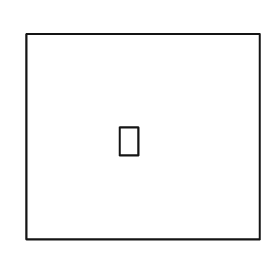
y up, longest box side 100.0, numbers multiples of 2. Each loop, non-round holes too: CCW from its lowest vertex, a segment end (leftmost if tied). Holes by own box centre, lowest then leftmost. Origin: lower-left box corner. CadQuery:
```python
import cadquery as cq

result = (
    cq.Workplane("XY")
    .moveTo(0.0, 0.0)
    .lineTo(100.0, 0.0)
    .lineTo(100.0, 88.0)
    .lineTo(0.0, 88.0)
    .close()
    .moveTo(40.0, 36.0)
    .lineTo(48.0, 36.0)
    .lineTo(48.0, 48.0)
    .lineTo(40.0, 48.0)
    .close()
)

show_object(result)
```